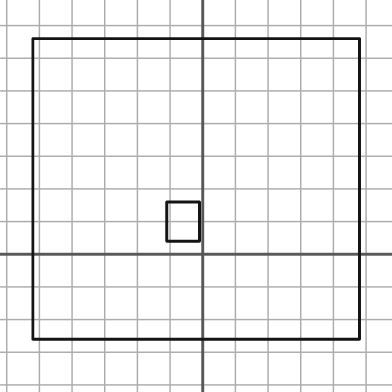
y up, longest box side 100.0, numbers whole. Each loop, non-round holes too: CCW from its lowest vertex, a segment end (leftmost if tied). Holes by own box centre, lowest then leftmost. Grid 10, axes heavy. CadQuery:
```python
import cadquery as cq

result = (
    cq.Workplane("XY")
    .moveTo(-52.0, -26.0)
    .lineTo(48.0, -26.0)
    .lineTo(48.0, 66.0)
    .lineTo(-52.0, 66.0)
    .close()
    .moveTo(-11.0, 4.0)
    .lineTo(-1.0, 4.0)
    .lineTo(-1.0, 16.0)
    .lineTo(-11.0, 16.0)
    .close()
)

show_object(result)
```